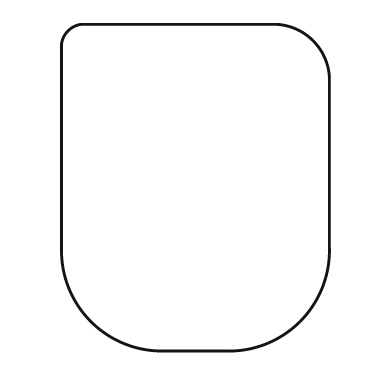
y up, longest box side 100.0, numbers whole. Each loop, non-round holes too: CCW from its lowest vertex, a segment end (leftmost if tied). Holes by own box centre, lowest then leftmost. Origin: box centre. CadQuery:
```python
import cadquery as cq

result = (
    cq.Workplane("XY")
    .moveTo(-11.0, -50.0)
    .lineTo(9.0, -50.0)
    .threePointArc((32.0, -41.0), (41.0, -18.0))
    .lineTo(41.0, 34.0)
    .threePointArc((36.0, 45.0), (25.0, 50.0))
    .lineTo(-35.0, 50.0)
    .threePointArc((-39.0, 48.0), (-41.0, 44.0))
    .lineTo(-41.0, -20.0)
    .threePointArc((-32.0, -41.0), (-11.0, -50.0))
    .close()
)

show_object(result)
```